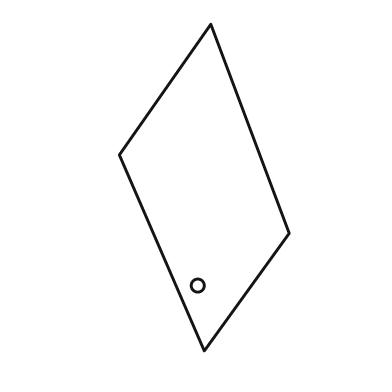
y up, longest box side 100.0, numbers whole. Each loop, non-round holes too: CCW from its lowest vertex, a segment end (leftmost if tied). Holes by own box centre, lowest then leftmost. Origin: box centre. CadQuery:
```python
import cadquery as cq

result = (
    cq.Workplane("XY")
    .moveTo(0.0, -50.0)
    .lineTo(26.0, -14.0)
    .lineTo(2.0, 50.0)
    .lineTo(-26.0, 10.0)
    .close()
    .moveTo(-2.0, -30.0)
    .circle(2.0)
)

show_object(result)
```